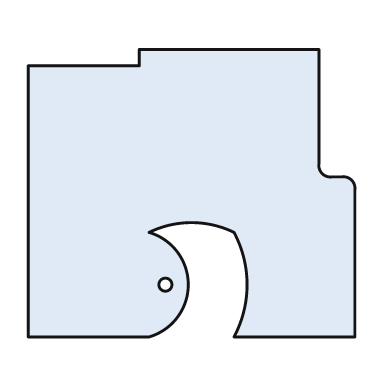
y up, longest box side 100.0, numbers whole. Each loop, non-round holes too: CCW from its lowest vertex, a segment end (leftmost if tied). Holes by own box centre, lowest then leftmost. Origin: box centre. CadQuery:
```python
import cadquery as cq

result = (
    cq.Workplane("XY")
    .moveTo(-50.0, -44.0)
    .lineTo(-13.0, -44.0)
    .threePointArc((-1.0, -28.0), (-13.0, -12.0))
    .threePointArc((0.0, -9.0), (13.0, -12.0))
    .threePointArc((17.0, -28.0), (13.0, -44.0))
    .lineTo(50.0, -44.0)
    .lineTo(50.0, 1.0)
    .threePointArc((49.0, 4.0), (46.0, 5.0))
    .lineTo(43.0, 5.0)
    .threePointArc((40.0, 6.0), (39.0, 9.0))
    .lineTo(39.0, 44.0)
    .lineTo(-16.0, 44.0)
    .lineTo(-16.0, 39.0)
    .lineTo(-50.0, 39.0)
    .close()
    .moveTo(-8.0, -28.0)
    .circle(2.0)
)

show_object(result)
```